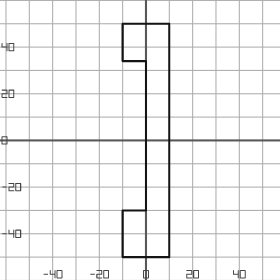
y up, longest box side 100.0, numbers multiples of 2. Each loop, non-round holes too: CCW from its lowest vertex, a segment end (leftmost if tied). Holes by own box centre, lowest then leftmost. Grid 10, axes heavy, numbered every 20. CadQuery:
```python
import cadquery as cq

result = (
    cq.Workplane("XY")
    .moveTo(-10.0, -50.0)
    .lineTo(10.0, -50.0)
    .lineTo(10.0, 50.0)
    .lineTo(-10.0, 50.0)
    .lineTo(-10.0, 34.0)
    .lineTo(0.0, 34.0)
    .lineTo(0.0, -30.0)
    .lineTo(-10.0, -30.0)
    .close()
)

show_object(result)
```